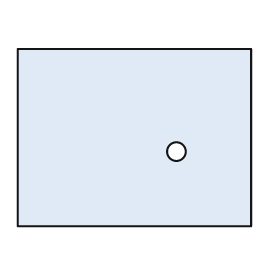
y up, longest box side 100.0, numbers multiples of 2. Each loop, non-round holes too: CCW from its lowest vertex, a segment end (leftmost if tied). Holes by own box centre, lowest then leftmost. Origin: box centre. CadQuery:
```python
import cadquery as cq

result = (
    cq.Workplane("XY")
    .moveTo(-50.0, -38.0)
    .lineTo(50.0, -38.0)
    .lineTo(50.0, 38.0)
    .lineTo(-50.0, 38.0)
    .close()
    .moveTo(18.0, -6.0)
    .circle(4.0)
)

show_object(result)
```